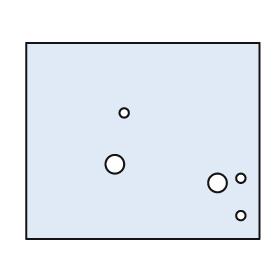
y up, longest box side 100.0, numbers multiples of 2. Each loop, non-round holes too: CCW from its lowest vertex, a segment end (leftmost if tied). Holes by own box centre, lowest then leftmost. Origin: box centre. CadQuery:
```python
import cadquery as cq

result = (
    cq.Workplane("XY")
    .moveTo(-50.0, -42.0)
    .lineTo(50.0, -42.0)
    .lineTo(50.0, 42.0)
    .lineTo(-50.0, 42.0)
    .close()
    .moveTo(42.0, -32.0)
    .circle(2.0)
    .moveTo(32.0, -18.0)
    .circle(4.0)
    .moveTo(42.0, -16.0)
    .circle(2.0)
    .moveTo(-12.0, -10.0)
    .circle(4.0)
    .moveTo(-8.0, 12.0)
    .circle(2.0)
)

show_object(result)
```